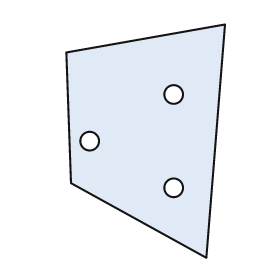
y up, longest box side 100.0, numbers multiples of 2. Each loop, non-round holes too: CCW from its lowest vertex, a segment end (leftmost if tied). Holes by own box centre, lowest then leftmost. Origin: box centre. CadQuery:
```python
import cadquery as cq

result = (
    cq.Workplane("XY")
    .moveTo(26.0, -50.0)
    .lineTo(34.0, 50.0)
    .lineTo(-34.0, 38.0)
    .lineTo(-32.0, -18.0)
    .close()
    .moveTo(12.0, -20.0)
    .circle(4.0)
    .moveTo(-24.0, 0.0)
    .circle(4.0)
    .moveTo(12.0, 20.0)
    .circle(4.0)
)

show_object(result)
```